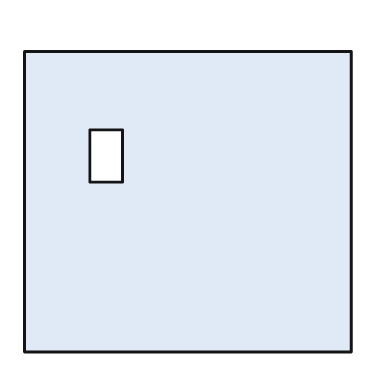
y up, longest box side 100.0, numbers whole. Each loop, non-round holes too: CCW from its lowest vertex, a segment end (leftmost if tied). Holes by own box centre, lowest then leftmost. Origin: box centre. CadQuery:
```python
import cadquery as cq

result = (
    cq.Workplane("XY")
    .moveTo(-50.0, -46.0)
    .lineTo(50.0, -46.0)
    .lineTo(50.0, 46.0)
    .lineTo(-50.0, 46.0)
    .close()
    .moveTo(-30.0, 6.0)
    .lineTo(-20.0, 6.0)
    .lineTo(-20.0, 22.0)
    .lineTo(-30.0, 22.0)
    .close()
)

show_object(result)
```